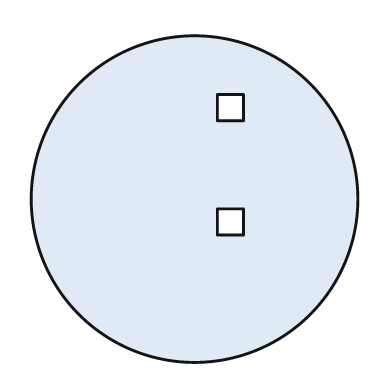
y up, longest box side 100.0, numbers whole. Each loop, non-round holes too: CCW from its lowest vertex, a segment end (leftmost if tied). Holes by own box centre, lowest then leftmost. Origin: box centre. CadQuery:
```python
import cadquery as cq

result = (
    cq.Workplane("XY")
    .moveTo(0.0, 0.0)
    .circle(50.0)
    .moveTo(7.0, -11.0)
    .lineTo(15.0, -11.0)
    .lineTo(15.0, -3.0)
    .lineTo(7.0, -3.0)
    .close()
    .moveTo(7.0, 24.0)
    .lineTo(15.0, 24.0)
    .lineTo(15.0, 32.0)
    .lineTo(7.0, 32.0)
    .close()
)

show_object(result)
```